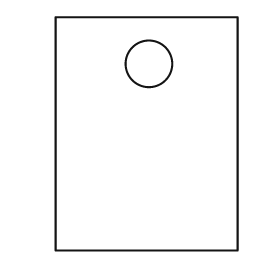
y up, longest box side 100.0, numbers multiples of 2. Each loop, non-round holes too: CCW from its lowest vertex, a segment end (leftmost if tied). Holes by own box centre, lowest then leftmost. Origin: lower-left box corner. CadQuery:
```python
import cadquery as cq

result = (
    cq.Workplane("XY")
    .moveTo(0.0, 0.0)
    .lineTo(78.0, 0.0)
    .lineTo(78.0, 100.0)
    .lineTo(0.0, 100.0)
    .close()
    .moveTo(40.0, 80.0)
    .circle(10.0)
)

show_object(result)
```